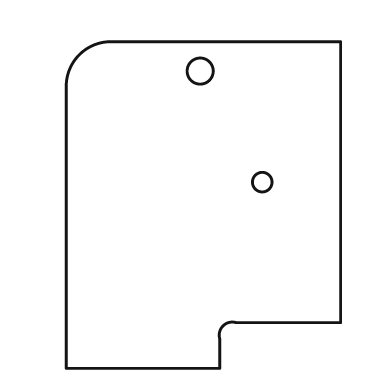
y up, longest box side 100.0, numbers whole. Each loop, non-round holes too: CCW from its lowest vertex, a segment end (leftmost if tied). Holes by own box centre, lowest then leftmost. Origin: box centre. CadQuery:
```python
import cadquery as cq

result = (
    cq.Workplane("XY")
    .moveTo(-42.0, -50.0)
    .lineTo(5.0, -50.0)
    .lineTo(5.0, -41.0)
    .threePointArc((6.0, -37.0), (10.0, -36.0))
    .lineTo(42.0, -36.0)
    .lineTo(42.0, 50.0)
    .lineTo(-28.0, 50.0)
    .threePointArc((-38.0, 46.0), (-42.0, 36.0))
    .close()
    .moveTo(18.0, 7.0)
    .circle(3.0)
    .moveTo(-1.0, 41.0)
    .circle(4.0)
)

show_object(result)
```